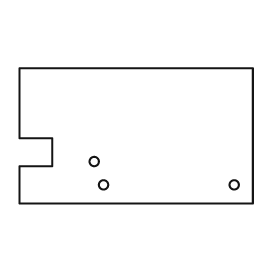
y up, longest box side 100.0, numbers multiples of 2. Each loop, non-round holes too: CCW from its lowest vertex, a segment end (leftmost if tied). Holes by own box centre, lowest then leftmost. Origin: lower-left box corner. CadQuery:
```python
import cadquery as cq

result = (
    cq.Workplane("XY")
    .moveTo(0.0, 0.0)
    .lineTo(100.0, 0.0)
    .lineTo(100.0, 58.0)
    .lineTo(0.0, 58.0)
    .lineTo(0.0, 28.0)
    .lineTo(14.0, 28.0)
    .lineTo(14.0, 16.0)
    .lineTo(0.0, 16.0)
    .close()
    .moveTo(36.0, 8.0)
    .circle(2.0)
    .moveTo(92.0, 8.0)
    .circle(2.0)
    .moveTo(32.0, 18.0)
    .circle(2.0)
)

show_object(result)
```